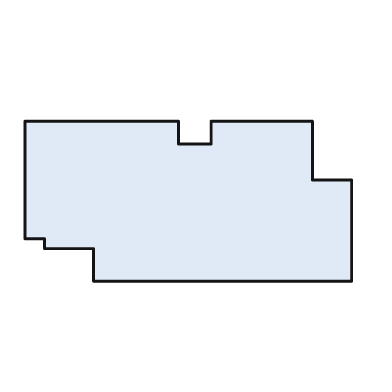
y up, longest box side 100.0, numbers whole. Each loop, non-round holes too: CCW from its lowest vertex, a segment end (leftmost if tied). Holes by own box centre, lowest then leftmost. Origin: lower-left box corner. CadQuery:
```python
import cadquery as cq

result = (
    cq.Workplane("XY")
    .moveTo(21.0, 0.0)
    .lineTo(100.0, 0.0)
    .lineTo(100.0, 31.0)
    .lineTo(88.0, 31.0)
    .lineTo(88.0, 49.0)
    .lineTo(57.0, 49.0)
    .lineTo(57.0, 42.0)
    .lineTo(47.0, 42.0)
    .lineTo(47.0, 49.0)
    .lineTo(0.0, 49.0)
    .lineTo(0.0, 13.0)
    .lineTo(6.0, 13.0)
    .lineTo(6.0, 10.0)
    .lineTo(21.0, 10.0)
    .close()
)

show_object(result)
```